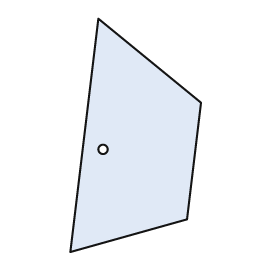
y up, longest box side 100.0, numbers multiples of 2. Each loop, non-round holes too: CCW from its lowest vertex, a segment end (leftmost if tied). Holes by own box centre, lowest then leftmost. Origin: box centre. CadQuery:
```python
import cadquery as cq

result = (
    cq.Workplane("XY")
    .moveTo(-28.0, -50.0)
    .lineTo(22.0, -36.0)
    .lineTo(28.0, 14.0)
    .lineTo(-16.0, 50.0)
    .close()
    .moveTo(-14.0, -6.0)
    .circle(2.0)
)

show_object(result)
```